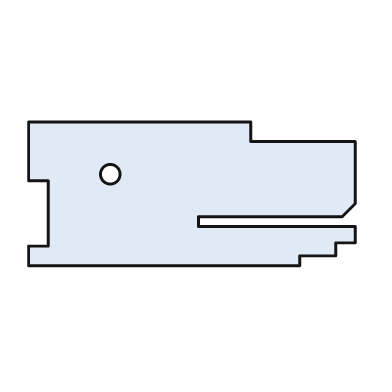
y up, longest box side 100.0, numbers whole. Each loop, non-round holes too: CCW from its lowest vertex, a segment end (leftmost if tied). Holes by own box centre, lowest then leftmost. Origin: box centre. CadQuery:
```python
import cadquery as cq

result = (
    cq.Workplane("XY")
    .moveTo(-50.0, -22.0)
    .lineTo(33.0, -22.0)
    .lineTo(33.0, -19.0)
    .lineTo(44.0, -19.0)
    .lineTo(44.0, -15.0)
    .lineTo(50.0, -15.0)
    .lineTo(50.0, -10.0)
    .lineTo(2.0, -10.0)
    .lineTo(2.0, -7.0)
    .lineTo(46.0, -7.0)
    .lineTo(50.0, -3.0)
    .lineTo(50.0, 16.0)
    .lineTo(18.0, 16.0)
    .lineTo(18.0, 22.0)
    .lineTo(-50.0, 22.0)
    .lineTo(-50.0, 4.0)
    .lineTo(-44.0, 4.0)
    .lineTo(-44.0, -16.0)
    .lineTo(-50.0, -16.0)
    .close()
    .moveTo(-25.0, 6.0)
    .circle(3.0)
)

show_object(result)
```